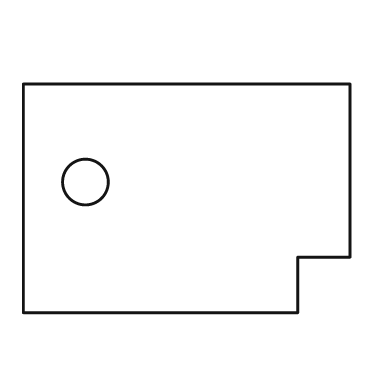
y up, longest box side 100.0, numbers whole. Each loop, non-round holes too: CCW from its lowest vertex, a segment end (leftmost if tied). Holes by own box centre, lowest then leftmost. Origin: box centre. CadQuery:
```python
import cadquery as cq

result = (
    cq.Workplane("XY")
    .moveTo(-50.0, -35.0)
    .lineTo(34.0, -35.0)
    .lineTo(34.0, -18.0)
    .lineTo(50.0, -18.0)
    .lineTo(50.0, 35.0)
    .lineTo(-50.0, 35.0)
    .close()
    .moveTo(-31.0, 5.0)
    .circle(7.0)
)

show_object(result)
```